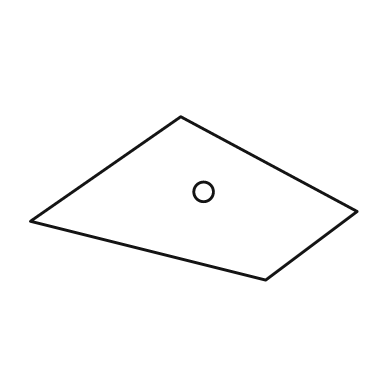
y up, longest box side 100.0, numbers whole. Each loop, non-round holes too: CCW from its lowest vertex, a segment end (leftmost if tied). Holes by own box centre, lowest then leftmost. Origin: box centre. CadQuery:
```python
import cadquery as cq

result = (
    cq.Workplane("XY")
    .moveTo(22.0, -25.0)
    .lineTo(50.0, -4.0)
    .lineTo(-4.0, 25.0)
    .lineTo(-50.0, -7.0)
    .close()
    .moveTo(3.0, 2.0)
    .circle(3.0)
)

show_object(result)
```